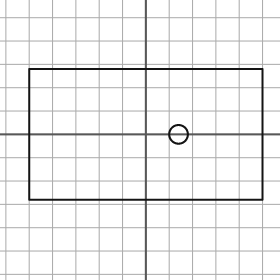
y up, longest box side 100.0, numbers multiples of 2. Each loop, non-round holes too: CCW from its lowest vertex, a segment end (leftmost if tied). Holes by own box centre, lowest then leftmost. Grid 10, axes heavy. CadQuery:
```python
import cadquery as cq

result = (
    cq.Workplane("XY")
    .moveTo(-50.0, -28.0)
    .lineTo(50.0, -28.0)
    .lineTo(50.0, 28.0)
    .lineTo(-50.0, 28.0)
    .close()
    .moveTo(14.0, 0.0)
    .circle(4.0)
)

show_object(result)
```